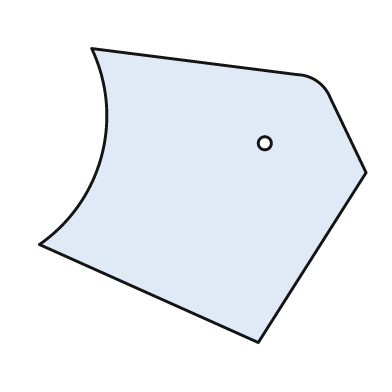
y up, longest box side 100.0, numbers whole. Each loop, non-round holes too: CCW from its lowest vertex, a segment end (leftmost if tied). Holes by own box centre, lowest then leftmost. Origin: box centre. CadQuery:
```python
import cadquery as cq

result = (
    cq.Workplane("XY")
    .moveTo(17.0, -45.0)
    .lineTo(50.0, 7.0)
    .lineTo(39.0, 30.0)
    .threePointArc((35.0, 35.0), (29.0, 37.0))
    .lineTo(-34.0, 45.0)
    .threePointArc((-31.0, 12.0), (-50.0, -15.0))
    .close()
    .moveTo(19.0, 16.0)
    .circle(2.0)
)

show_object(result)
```